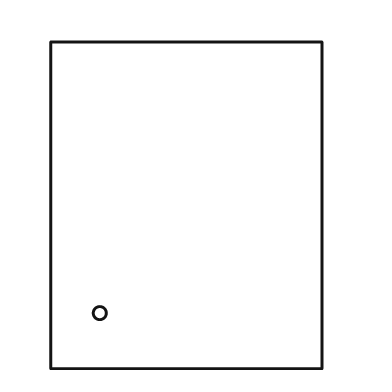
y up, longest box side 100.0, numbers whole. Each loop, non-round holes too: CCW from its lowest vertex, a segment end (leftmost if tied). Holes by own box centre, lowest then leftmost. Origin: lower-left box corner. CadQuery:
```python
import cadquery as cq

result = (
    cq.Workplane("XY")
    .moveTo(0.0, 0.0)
    .lineTo(83.0, 0.0)
    .lineTo(83.0, 100.0)
    .lineTo(0.0, 100.0)
    .close()
    .moveTo(15.0, 17.0)
    .circle(2.0)
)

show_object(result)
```